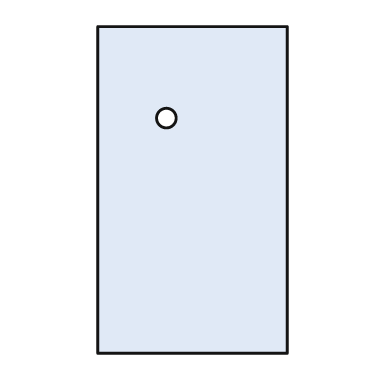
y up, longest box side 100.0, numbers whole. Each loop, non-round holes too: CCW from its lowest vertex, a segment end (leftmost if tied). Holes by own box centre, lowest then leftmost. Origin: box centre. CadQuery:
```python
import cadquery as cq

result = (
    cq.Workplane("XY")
    .moveTo(-29.0, -50.0)
    .lineTo(29.0, -50.0)
    .lineTo(29.0, 50.0)
    .lineTo(-29.0, 50.0)
    .close()
    .moveTo(-8.0, 22.0)
    .circle(3.0)
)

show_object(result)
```